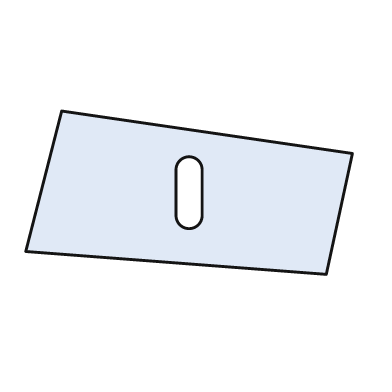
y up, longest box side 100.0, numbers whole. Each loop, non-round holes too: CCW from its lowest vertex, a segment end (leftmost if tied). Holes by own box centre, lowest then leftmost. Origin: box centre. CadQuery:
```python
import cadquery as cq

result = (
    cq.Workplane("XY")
    .moveTo(42.0, -25.0)
    .lineTo(50.0, 12.0)
    .lineTo(-39.0, 25.0)
    .lineTo(-50.0, -18.0)
    .close()
    .moveTo(-4.0, -7.0)
    .threePointArc((0.0, -11.0), (4.0, -7.0))
    .lineTo(4.0, 7.0)
    .threePointArc((0.0, 11.0), (-4.0, 7.0))
    .close()
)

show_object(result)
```